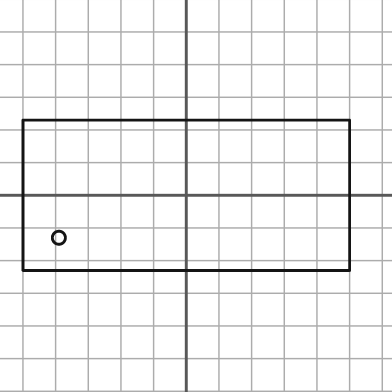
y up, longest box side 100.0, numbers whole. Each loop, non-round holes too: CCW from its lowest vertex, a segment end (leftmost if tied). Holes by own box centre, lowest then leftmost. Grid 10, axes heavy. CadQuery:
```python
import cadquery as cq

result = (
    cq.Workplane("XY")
    .moveTo(-50.0, -23.0)
    .lineTo(50.0, -23.0)
    .lineTo(50.0, 23.0)
    .lineTo(-50.0, 23.0)
    .close()
    .moveTo(-39.0, -13.0)
    .circle(2.0)
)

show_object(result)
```